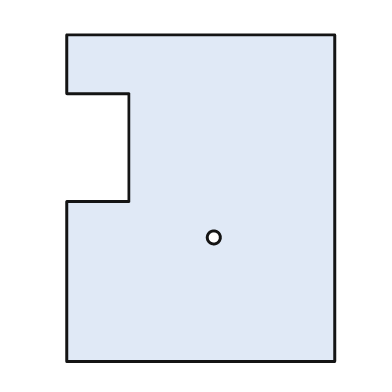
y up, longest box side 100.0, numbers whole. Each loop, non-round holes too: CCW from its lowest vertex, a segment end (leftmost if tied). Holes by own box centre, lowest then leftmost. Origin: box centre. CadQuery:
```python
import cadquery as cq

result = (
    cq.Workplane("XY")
    .moveTo(-41.0, -50.0)
    .lineTo(41.0, -50.0)
    .lineTo(41.0, 50.0)
    .lineTo(-41.0, 50.0)
    .lineTo(-41.0, 32.0)
    .lineTo(-22.0, 32.0)
    .lineTo(-22.0, -1.0)
    .lineTo(-41.0, -1.0)
    .close()
    .moveTo(4.0, -12.0)
    .circle(2.0)
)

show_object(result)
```